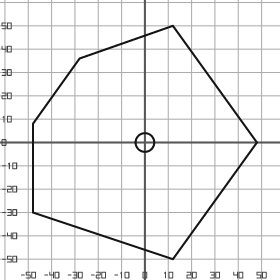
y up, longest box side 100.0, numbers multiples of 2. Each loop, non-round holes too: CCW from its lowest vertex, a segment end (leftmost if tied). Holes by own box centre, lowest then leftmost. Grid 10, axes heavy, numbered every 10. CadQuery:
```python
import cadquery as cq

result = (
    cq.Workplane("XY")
    .moveTo(12.0, -50.0)
    .lineTo(48.0, 0.0)
    .lineTo(12.0, 50.0)
    .lineTo(-28.0, 36.0)
    .lineTo(-48.0, 8.0)
    .lineTo(-48.0, -30.0)
    .close()
    .moveTo(0.0, 0.0)
    .circle(4.0)
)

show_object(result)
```